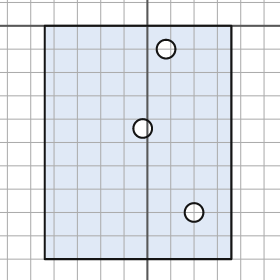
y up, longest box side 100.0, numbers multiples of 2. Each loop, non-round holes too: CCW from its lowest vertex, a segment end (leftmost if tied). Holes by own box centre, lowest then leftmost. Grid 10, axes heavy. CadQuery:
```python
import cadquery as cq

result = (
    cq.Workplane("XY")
    .moveTo(-44.0, -100.0)
    .lineTo(36.0, -100.0)
    .lineTo(36.0, 0.0)
    .lineTo(-44.0, 0.0)
    .close()
    .moveTo(20.0, -80.0)
    .circle(4.0)
    .moveTo(-2.0, -44.0)
    .circle(4.0)
    .moveTo(8.0, -10.0)
    .circle(4.0)
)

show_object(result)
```